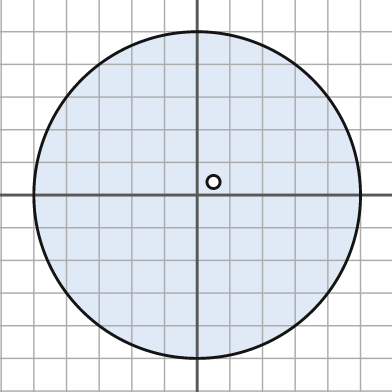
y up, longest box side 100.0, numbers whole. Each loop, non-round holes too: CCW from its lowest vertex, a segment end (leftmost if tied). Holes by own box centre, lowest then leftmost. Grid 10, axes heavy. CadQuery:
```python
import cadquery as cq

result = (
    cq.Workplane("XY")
    .moveTo(0.0, 0.0)
    .circle(50.0)
    .moveTo(5.0, 4.0)
    .circle(2.0)
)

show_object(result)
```